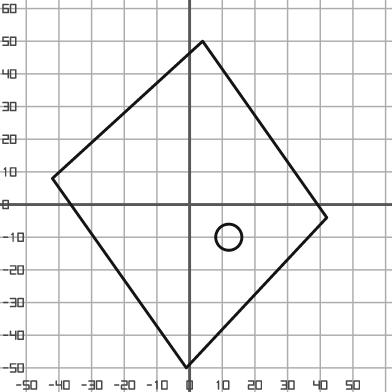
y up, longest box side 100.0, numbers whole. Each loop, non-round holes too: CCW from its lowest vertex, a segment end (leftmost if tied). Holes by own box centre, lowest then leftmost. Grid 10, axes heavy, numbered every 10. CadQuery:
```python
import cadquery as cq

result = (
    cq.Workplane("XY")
    .moveTo(-1.0, -50.0)
    .lineTo(42.0, -4.0)
    .lineTo(4.0, 50.0)
    .lineTo(-42.0, 8.0)
    .close()
    .moveTo(12.0, -10.0)
    .circle(4.0)
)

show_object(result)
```